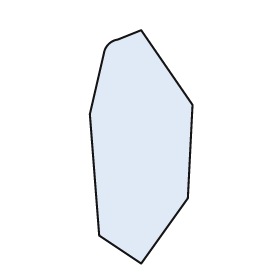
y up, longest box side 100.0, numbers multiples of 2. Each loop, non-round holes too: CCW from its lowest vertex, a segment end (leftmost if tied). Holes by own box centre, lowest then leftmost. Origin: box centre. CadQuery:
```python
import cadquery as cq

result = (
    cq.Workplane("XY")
    .moveTo(0.0, -50.0)
    .lineTo(20.0, -22.0)
    .lineTo(22.0, 18.0)
    .lineTo(0.0, 50.0)
    .lineTo(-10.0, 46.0)
    .threePointArc((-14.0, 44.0), (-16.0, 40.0))
    .lineTo(-22.0, 14.0)
    .lineTo(-18.0, -38.0)
    .close()
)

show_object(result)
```